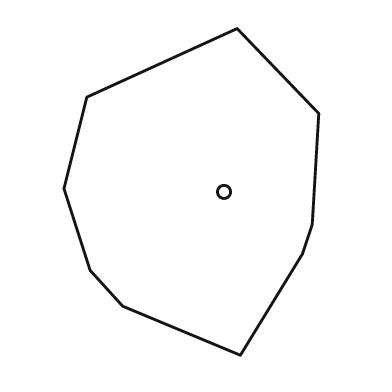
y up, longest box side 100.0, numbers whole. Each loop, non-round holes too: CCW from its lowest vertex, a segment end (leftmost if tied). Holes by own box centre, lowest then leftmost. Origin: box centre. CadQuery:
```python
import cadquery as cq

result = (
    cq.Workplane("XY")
    .moveTo(15.0, -50.0)
    .lineTo(34.0, -19.0)
    .lineTo(37.0, -10.0)
    .lineTo(39.0, 24.0)
    .lineTo(14.0, 50.0)
    .lineTo(-32.0, 29.0)
    .lineTo(-39.0, 1.0)
    .lineTo(-31.0, -24.0)
    .lineTo(-21.0, -35.0)
    .close()
    .moveTo(10.0, 0.0)
    .circle(2.0)
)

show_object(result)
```